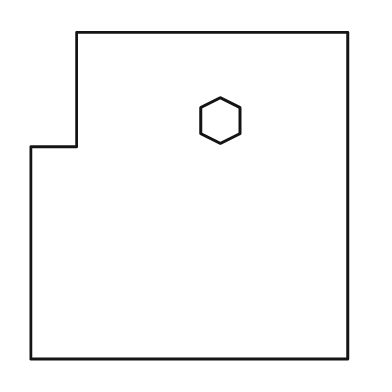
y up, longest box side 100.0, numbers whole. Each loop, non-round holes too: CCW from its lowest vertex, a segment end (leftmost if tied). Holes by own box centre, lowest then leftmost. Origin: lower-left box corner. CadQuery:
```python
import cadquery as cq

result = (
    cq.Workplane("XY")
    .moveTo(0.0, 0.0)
    .lineTo(97.0, 0.0)
    .lineTo(97.0, 100.0)
    .lineTo(14.0, 100.0)
    .lineTo(14.0, 65.0)
    .lineTo(0.0, 65.0)
    .close()
    .moveTo(58.0, 66.0)
    .lineTo(64.0, 69.0)
    .lineTo(64.0, 77.0)
    .lineTo(58.0, 80.0)
    .lineTo(52.0, 77.0)
    .lineTo(52.0, 69.0)
    .close()
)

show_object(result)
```